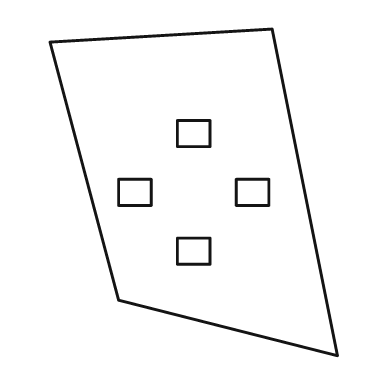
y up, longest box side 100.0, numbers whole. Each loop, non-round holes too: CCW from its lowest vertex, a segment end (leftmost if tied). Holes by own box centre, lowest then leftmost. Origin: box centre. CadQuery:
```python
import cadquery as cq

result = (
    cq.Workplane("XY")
    .moveTo(44.0, -50.0)
    .lineTo(24.0, 50.0)
    .lineTo(-44.0, 46.0)
    .lineTo(-23.0, -33.0)
    .close()
    .moveTo(-5.0, -22.0)
    .lineTo(5.0, -22.0)
    .lineTo(5.0, -14.0)
    .lineTo(-5.0, -14.0)
    .close()
    .moveTo(-23.0, -4.0)
    .lineTo(-13.0, -4.0)
    .lineTo(-13.0, 4.0)
    .lineTo(-23.0, 4.0)
    .close()
    .moveTo(13.0, -4.0)
    .lineTo(23.0, -4.0)
    .lineTo(23.0, 4.0)
    .lineTo(13.0, 4.0)
    .close()
    .moveTo(-5.0, 14.0)
    .lineTo(5.0, 14.0)
    .lineTo(5.0, 22.0)
    .lineTo(-5.0, 22.0)
    .close()
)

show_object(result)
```